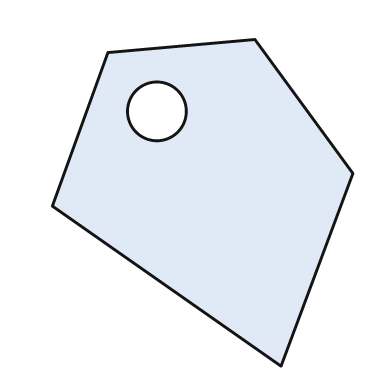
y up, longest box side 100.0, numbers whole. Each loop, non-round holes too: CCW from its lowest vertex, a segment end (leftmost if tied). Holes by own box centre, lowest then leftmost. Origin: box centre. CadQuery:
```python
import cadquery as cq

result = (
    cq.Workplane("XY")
    .moveTo(24.0, -50.0)
    .lineTo(46.0, 9.0)
    .lineTo(16.0, 50.0)
    .lineTo(-29.0, 46.0)
    .lineTo(-46.0, -1.0)
    .close()
    .moveTo(-14.0, 28.0)
    .circle(9.0)
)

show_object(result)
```